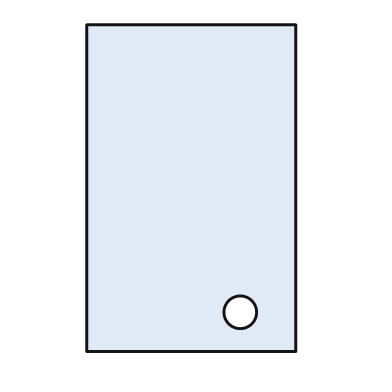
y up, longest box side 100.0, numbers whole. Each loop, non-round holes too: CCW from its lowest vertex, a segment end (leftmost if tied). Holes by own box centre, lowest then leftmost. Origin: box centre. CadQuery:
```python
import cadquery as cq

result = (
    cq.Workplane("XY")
    .moveTo(-32.0, -50.0)
    .lineTo(32.0, -50.0)
    .lineTo(32.0, 50.0)
    .lineTo(-32.0, 50.0)
    .close()
    .moveTo(15.0, -38.0)
    .circle(5.0)
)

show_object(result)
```